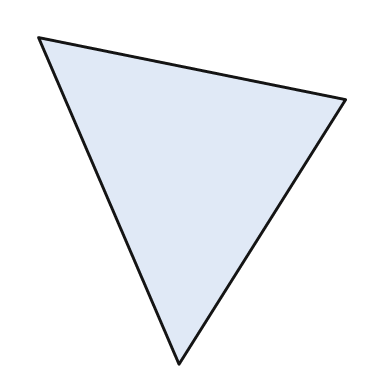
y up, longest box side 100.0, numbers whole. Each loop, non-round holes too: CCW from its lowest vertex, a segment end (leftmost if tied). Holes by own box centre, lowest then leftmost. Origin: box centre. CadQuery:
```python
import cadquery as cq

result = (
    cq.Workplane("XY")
    .moveTo(-4.0, -50.0)
    .lineTo(47.0, 31.0)
    .lineTo(-47.0, 50.0)
    .close()
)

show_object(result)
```